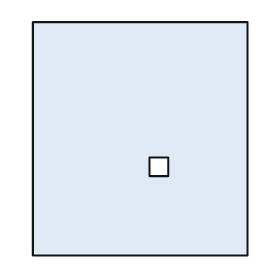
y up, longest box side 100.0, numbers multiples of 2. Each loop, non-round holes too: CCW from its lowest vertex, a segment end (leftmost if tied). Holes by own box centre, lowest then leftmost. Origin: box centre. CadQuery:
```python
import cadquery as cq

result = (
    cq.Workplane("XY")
    .moveTo(-46.0, -50.0)
    .lineTo(46.0, -50.0)
    .lineTo(46.0, 50.0)
    .lineTo(-46.0, 50.0)
    .close()
    .moveTo(4.0, -16.0)
    .lineTo(12.0, -16.0)
    .lineTo(12.0, -8.0)
    .lineTo(4.0, -8.0)
    .close()
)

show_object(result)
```